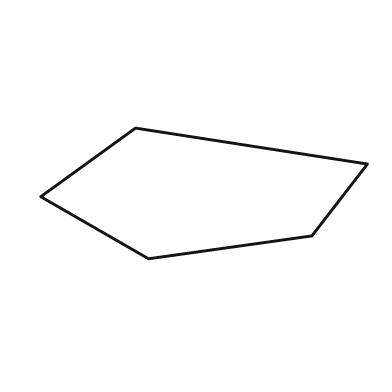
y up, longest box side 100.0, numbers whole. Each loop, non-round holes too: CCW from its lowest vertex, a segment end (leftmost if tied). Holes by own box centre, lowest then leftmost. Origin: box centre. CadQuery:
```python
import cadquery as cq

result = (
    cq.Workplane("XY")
    .moveTo(-17.0, -20.0)
    .lineTo(33.0, -13.0)
    .lineTo(50.0, 9.0)
    .lineTo(-21.0, 20.0)
    .lineTo(-50.0, -1.0)
    .close()
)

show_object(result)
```